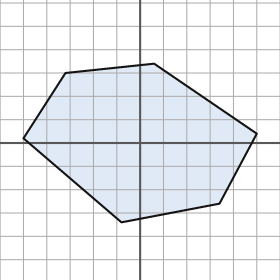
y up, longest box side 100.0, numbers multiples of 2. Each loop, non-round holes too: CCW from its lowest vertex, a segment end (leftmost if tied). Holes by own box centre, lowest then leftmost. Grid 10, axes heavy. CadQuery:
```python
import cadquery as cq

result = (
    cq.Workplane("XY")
    .moveTo(-8.0, -34.0)
    .lineTo(34.0, -26.0)
    .lineTo(50.0, 4.0)
    .lineTo(6.0, 34.0)
    .lineTo(-32.0, 30.0)
    .lineTo(-50.0, 2.0)
    .close()
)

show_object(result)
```